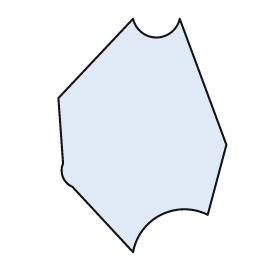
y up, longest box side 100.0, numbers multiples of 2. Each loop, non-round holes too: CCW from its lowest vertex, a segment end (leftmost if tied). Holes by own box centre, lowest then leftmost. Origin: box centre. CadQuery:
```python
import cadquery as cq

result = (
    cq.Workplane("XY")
    .moveTo(-4.0, -50.0)
    .threePointArc((8.0, -34.0), (28.0, -34.0))
    .lineTo(36.0, -4.0)
    .lineTo(16.0, 50.0)
    .threePointArc((6.0, 42.0), (-4.0, 50.0))
    .lineTo(-36.0, 16.0)
    .lineTo(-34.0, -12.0)
    .threePointArc((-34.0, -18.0), (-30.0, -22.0))
    .close()
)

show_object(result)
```